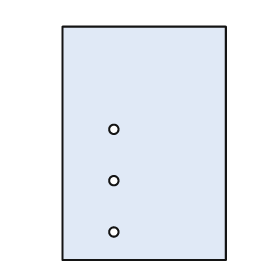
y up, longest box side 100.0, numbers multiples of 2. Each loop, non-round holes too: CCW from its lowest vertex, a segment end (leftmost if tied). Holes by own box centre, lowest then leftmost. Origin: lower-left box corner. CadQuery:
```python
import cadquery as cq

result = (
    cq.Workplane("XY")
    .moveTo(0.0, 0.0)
    .lineTo(70.0, 0.0)
    .lineTo(70.0, 100.0)
    .lineTo(0.0, 100.0)
    .close()
    .moveTo(22.0, 12.0)
    .circle(2.0)
    .moveTo(22.0, 34.0)
    .circle(2.0)
    .moveTo(22.0, 56.0)
    .circle(2.0)
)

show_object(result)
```